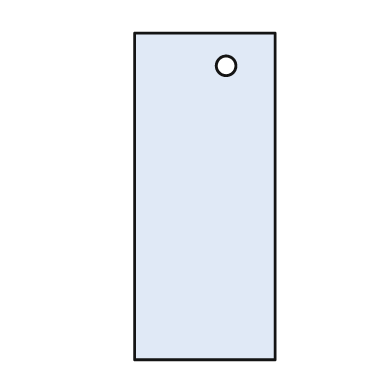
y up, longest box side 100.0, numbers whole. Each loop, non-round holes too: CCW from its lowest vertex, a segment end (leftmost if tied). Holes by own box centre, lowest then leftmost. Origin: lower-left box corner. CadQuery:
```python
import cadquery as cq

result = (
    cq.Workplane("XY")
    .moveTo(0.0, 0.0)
    .lineTo(43.0, 0.0)
    .lineTo(43.0, 100.0)
    .lineTo(0.0, 100.0)
    .close()
    .moveTo(28.0, 90.0)
    .circle(3.0)
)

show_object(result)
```